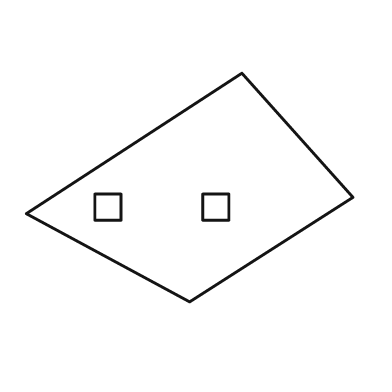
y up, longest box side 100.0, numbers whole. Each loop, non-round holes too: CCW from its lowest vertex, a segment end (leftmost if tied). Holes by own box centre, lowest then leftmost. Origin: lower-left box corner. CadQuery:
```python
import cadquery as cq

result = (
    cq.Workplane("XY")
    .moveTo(50.0, 0.0)
    .lineTo(100.0, 32.0)
    .lineTo(66.0, 70.0)
    .lineTo(0.0, 27.0)
    .close()
    .moveTo(21.0, 25.0)
    .lineTo(29.0, 25.0)
    .lineTo(29.0, 33.0)
    .lineTo(21.0, 33.0)
    .close()
    .moveTo(54.0, 25.0)
    .lineTo(62.0, 25.0)
    .lineTo(62.0, 33.0)
    .lineTo(54.0, 33.0)
    .close()
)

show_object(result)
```